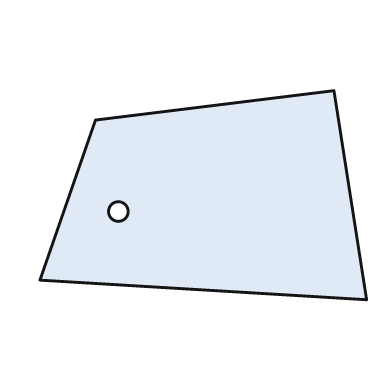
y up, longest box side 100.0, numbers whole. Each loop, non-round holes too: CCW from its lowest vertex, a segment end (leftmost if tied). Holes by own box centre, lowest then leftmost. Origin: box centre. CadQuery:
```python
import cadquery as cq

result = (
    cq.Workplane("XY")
    .moveTo(50.0, -32.0)
    .lineTo(40.0, 32.0)
    .lineTo(-33.0, 23.0)
    .lineTo(-50.0, -26.0)
    .close()
    .moveTo(-26.0, -5.0)
    .circle(3.0)
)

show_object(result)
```